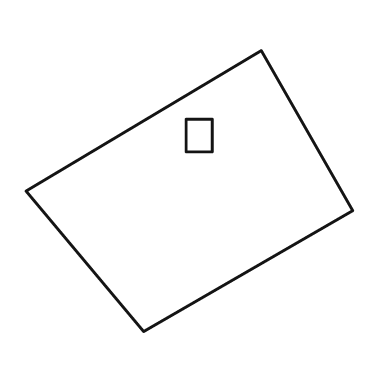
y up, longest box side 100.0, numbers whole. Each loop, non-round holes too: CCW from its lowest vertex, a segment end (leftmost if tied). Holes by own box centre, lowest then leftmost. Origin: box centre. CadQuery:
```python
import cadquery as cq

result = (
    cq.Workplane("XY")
    .moveTo(-14.0, -43.0)
    .lineTo(50.0, -6.0)
    .lineTo(22.0, 43.0)
    .lineTo(-50.0, 0.0)
    .close()
    .moveTo(-1.0, 12.0)
    .lineTo(7.0, 12.0)
    .lineTo(7.0, 22.0)
    .lineTo(-1.0, 22.0)
    .close()
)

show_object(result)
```